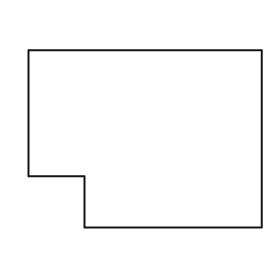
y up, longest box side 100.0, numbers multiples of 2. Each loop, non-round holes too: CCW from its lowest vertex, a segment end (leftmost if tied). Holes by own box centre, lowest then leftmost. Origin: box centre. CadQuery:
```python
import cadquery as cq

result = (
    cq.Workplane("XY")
    .moveTo(-26.0, -38.0)
    .lineTo(50.0, -38.0)
    .lineTo(50.0, 38.0)
    .lineTo(-50.0, 38.0)
    .lineTo(-50.0, -16.0)
    .lineTo(-26.0, -16.0)
    .close()
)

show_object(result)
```